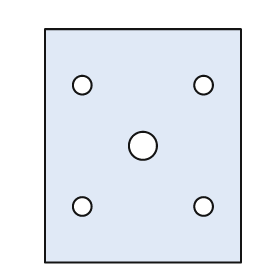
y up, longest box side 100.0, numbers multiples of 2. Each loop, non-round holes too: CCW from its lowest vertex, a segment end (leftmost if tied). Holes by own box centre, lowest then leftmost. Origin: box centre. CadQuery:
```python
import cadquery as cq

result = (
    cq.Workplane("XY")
    .moveTo(-42.0, -50.0)
    .lineTo(42.0, -50.0)
    .lineTo(42.0, 50.0)
    .lineTo(-42.0, 50.0)
    .close()
    .moveTo(-26.0, -26.0)
    .circle(4.0)
    .moveTo(26.0, -26.0)
    .circle(4.0)
    .moveTo(0.0, 0.0)
    .circle(6.0)
    .moveTo(-26.0, 26.0)
    .circle(4.0)
    .moveTo(26.0, 26.0)
    .circle(4.0)
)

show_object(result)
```